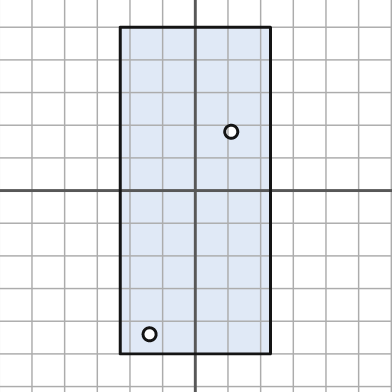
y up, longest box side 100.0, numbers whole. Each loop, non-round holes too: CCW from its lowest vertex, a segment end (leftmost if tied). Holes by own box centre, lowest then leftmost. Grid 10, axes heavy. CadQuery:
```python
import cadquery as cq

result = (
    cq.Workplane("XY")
    .moveTo(-23.0, -50.0)
    .lineTo(23.0, -50.0)
    .lineTo(23.0, 50.0)
    .lineTo(-23.0, 50.0)
    .close()
    .moveTo(-14.0, -44.0)
    .circle(2.0)
    .moveTo(11.0, 18.0)
    .circle(2.0)
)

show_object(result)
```